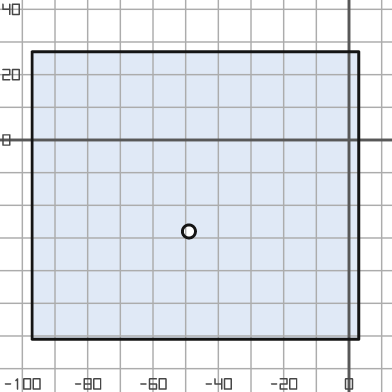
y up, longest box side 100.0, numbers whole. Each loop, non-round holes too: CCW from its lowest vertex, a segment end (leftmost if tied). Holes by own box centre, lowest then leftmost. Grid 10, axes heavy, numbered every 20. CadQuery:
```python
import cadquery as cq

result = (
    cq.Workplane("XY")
    .moveTo(-97.0, -61.0)
    .lineTo(3.0, -61.0)
    .lineTo(3.0, 27.0)
    .lineTo(-97.0, 27.0)
    .close()
    .moveTo(-49.0, -28.0)
    .circle(2.0)
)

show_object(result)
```